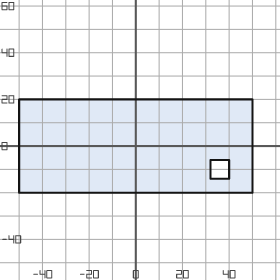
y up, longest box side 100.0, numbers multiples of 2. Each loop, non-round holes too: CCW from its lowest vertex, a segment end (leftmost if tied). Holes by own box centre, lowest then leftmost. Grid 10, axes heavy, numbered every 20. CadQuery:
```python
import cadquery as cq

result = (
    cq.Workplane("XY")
    .moveTo(-50.0, -20.0)
    .lineTo(50.0, -20.0)
    .lineTo(50.0, 20.0)
    .lineTo(-50.0, 20.0)
    .close()
    .moveTo(32.0, -14.0)
    .lineTo(40.0, -14.0)
    .lineTo(40.0, -6.0)
    .lineTo(32.0, -6.0)
    .close()
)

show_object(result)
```